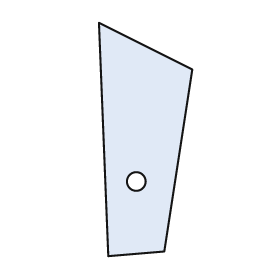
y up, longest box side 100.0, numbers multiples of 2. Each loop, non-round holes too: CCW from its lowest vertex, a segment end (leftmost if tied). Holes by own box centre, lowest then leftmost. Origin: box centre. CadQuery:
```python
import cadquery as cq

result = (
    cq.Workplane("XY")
    .moveTo(-16.0, -50.0)
    .lineTo(8.0, -48.0)
    .lineTo(20.0, 30.0)
    .lineTo(-20.0, 50.0)
    .close()
    .moveTo(-4.0, -18.0)
    .circle(4.0)
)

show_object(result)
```